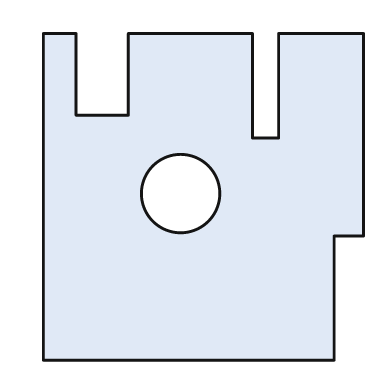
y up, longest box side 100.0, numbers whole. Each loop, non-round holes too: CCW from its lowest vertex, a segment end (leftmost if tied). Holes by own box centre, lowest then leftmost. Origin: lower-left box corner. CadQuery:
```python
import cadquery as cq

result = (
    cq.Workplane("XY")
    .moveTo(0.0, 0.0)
    .lineTo(89.0, 0.0)
    .lineTo(89.0, 38.0)
    .lineTo(98.0, 38.0)
    .lineTo(98.0, 100.0)
    .lineTo(72.0, 100.0)
    .lineTo(72.0, 68.0)
    .lineTo(64.0, 68.0)
    .lineTo(64.0, 100.0)
    .lineTo(26.0, 100.0)
    .lineTo(26.0, 75.0)
    .lineTo(10.0, 75.0)
    .lineTo(10.0, 100.0)
    .lineTo(0.0, 100.0)
    .close()
    .moveTo(42.0, 51.0)
    .circle(12.0)
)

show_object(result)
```